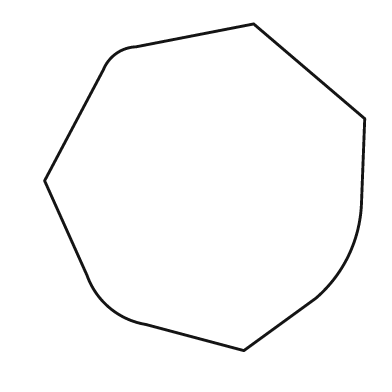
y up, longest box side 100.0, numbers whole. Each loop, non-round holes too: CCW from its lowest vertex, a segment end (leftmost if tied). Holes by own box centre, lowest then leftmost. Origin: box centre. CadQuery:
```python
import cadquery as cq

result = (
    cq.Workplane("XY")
    .moveTo(12.0, -50.0)
    .lineTo(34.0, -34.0)
    .threePointArc((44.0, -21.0), (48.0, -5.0))
    .lineTo(49.0, 21.0)
    .lineTo(15.0, 50.0)
    .lineTo(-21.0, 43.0)
    .threePointArc((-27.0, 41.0), (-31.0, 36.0))
    .lineTo(-49.0, 2.0)
    .lineTo(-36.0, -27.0)
    .threePointArc((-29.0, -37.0), (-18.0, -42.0))
    .close()
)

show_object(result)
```